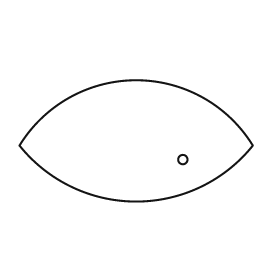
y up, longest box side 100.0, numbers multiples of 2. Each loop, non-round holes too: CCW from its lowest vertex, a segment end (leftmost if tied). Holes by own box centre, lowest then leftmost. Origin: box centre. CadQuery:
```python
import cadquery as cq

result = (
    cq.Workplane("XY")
    .moveTo(-50.0, -2.0)
    .threePointArc((0.0, -26.0), (50.0, -2.0))
    .threePointArc((0.0, 26.0), (-50.0, -2.0))
    .close()
    .moveTo(20.0, -8.0)
    .circle(2.0)
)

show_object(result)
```